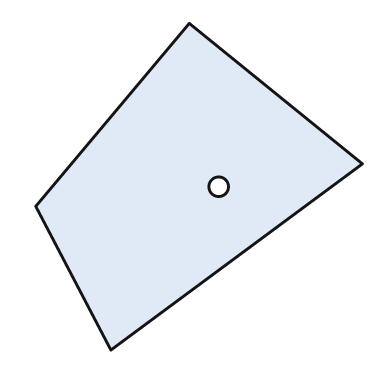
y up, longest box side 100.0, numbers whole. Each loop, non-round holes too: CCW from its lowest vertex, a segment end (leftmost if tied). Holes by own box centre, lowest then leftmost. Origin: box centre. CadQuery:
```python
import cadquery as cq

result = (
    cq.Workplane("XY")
    .moveTo(-27.0, -50.0)
    .lineTo(50.0, 7.0)
    .lineTo(-3.0, 50.0)
    .lineTo(-50.0, -6.0)
    .close()
    .moveTo(6.0, 0.0)
    .circle(3.0)
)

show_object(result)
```